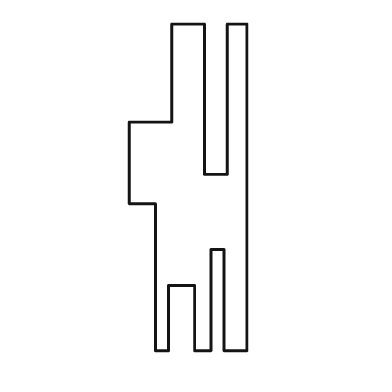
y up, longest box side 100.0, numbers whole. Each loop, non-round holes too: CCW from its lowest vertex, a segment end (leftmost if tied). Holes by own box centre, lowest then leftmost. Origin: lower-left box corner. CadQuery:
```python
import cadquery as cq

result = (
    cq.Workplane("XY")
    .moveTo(8.0, 0.0)
    .lineTo(12.0, 0.0)
    .lineTo(12.0, 20.0)
    .lineTo(20.0, 20.0)
    .lineTo(20.0, 0.0)
    .lineTo(25.0, 0.0)
    .lineTo(25.0, 31.0)
    .lineTo(29.0, 31.0)
    .lineTo(29.0, 0.0)
    .lineTo(36.0, 0.0)
    .lineTo(36.0, 100.0)
    .lineTo(30.0, 100.0)
    .lineTo(30.0, 54.0)
    .lineTo(23.0, 54.0)
    .lineTo(23.0, 100.0)
    .lineTo(13.0, 100.0)
    .lineTo(13.0, 70.0)
    .lineTo(0.0, 70.0)
    .lineTo(0.0, 45.0)
    .lineTo(8.0, 45.0)
    .close()
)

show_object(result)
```